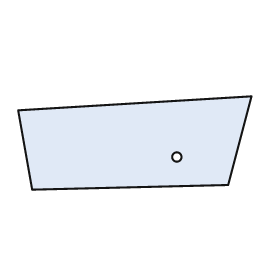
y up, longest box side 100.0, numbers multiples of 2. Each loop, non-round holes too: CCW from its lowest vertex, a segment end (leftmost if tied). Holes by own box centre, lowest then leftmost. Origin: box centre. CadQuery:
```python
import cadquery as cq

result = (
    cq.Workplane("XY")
    .moveTo(-44.0, -20.0)
    .lineTo(40.0, -18.0)
    .lineTo(50.0, 20.0)
    .lineTo(-50.0, 14.0)
    .close()
    .moveTo(18.0, -6.0)
    .circle(2.0)
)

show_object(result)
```